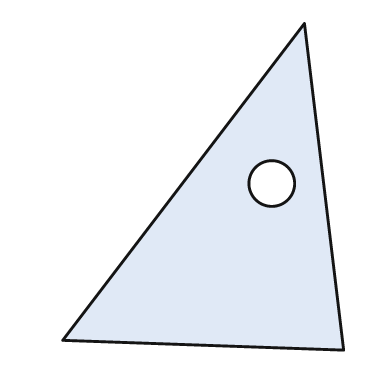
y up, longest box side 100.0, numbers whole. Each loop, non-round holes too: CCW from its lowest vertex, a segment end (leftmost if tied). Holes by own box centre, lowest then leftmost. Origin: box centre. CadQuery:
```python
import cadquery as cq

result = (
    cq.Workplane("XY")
    .moveTo(43.0, -50.0)
    .lineTo(31.0, 50.0)
    .lineTo(-43.0, -47.0)
    .close()
    .moveTo(21.0, 1.0)
    .circle(7.0)
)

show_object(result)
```